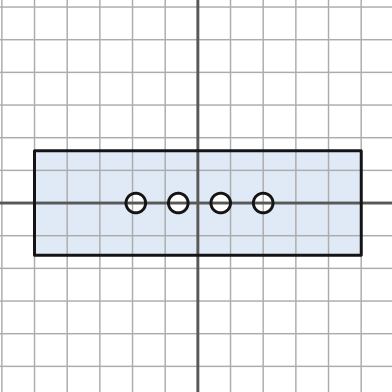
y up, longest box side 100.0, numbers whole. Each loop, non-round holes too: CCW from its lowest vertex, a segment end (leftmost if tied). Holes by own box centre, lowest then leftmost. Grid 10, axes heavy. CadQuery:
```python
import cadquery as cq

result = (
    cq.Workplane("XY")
    .moveTo(-50.0, -16.0)
    .lineTo(50.0, -16.0)
    .lineTo(50.0, 16.0)
    .lineTo(-50.0, 16.0)
    .close()
    .moveTo(-19.0, 0.0)
    .circle(3.0)
    .moveTo(-6.0, 0.0)
    .circle(3.0)
    .moveTo(7.0, 0.0)
    .circle(3.0)
    .moveTo(20.0, 0.0)
    .circle(3.0)
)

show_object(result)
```